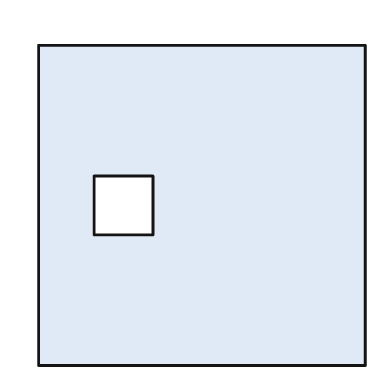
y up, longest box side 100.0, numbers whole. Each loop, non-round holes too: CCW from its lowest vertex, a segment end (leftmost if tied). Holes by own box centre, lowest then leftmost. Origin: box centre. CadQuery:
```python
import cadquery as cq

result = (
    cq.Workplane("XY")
    .moveTo(-50.0, -49.0)
    .lineTo(50.0, -49.0)
    .lineTo(50.0, 49.0)
    .lineTo(-50.0, 49.0)
    .close()
    .moveTo(-33.0, -9.0)
    .lineTo(-15.0, -9.0)
    .lineTo(-15.0, 9.0)
    .lineTo(-33.0, 9.0)
    .close()
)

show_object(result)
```